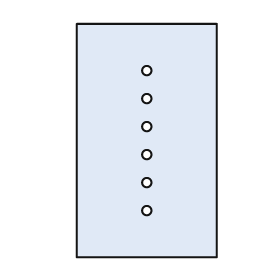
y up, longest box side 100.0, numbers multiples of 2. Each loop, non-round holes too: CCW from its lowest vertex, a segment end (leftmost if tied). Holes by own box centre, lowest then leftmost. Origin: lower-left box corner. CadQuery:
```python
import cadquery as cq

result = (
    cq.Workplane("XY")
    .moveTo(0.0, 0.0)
    .lineTo(60.0, 0.0)
    .lineTo(60.0, 100.0)
    .lineTo(0.0, 100.0)
    .close()
    .moveTo(30.0, 20.0)
    .circle(2.0)
    .moveTo(30.0, 32.0)
    .circle(2.0)
    .moveTo(30.0, 44.0)
    .circle(2.0)
    .moveTo(30.0, 56.0)
    .circle(2.0)
    .moveTo(30.0, 68.0)
    .circle(2.0)
    .moveTo(30.0, 80.0)
    .circle(2.0)
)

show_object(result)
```